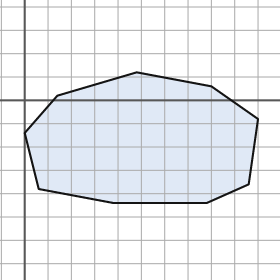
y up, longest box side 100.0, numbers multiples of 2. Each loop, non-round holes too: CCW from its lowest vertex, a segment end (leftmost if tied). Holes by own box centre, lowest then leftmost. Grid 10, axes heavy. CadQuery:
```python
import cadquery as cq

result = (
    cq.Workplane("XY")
    .moveTo(38.0, -44.0)
    .lineTo(78.0, -44.0)
    .lineTo(96.0, -36.0)
    .lineTo(100.0, -8.0)
    .lineTo(80.0, 6.0)
    .lineTo(48.0, 12.0)
    .lineTo(14.0, 2.0)
    .lineTo(0.0, -14.0)
    .lineTo(6.0, -38.0)
    .close()
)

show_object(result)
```